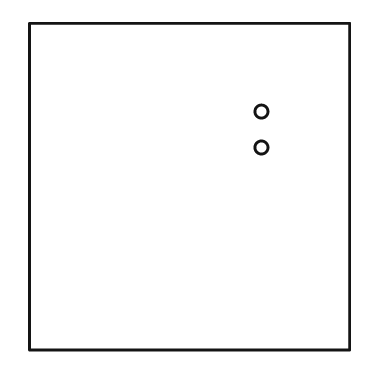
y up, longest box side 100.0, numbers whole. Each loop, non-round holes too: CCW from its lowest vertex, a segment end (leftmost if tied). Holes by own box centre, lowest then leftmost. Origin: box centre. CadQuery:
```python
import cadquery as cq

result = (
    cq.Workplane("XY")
    .moveTo(-49.0, -50.0)
    .lineTo(49.0, -50.0)
    .lineTo(49.0, 50.0)
    .lineTo(-49.0, 50.0)
    .close()
    .moveTo(22.0, 12.0)
    .circle(2.0)
    .moveTo(22.0, 23.0)
    .circle(2.0)
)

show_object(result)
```